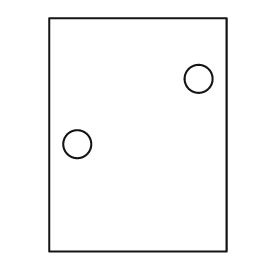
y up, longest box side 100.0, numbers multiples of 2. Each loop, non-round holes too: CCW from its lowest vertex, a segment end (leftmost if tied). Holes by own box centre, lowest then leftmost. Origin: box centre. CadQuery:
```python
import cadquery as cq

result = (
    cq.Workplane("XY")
    .moveTo(-38.0, -50.0)
    .lineTo(38.0, -50.0)
    .lineTo(38.0, 50.0)
    .lineTo(-38.0, 50.0)
    .close()
    .moveTo(-26.0, -4.0)
    .circle(6.0)
    .moveTo(26.0, 24.0)
    .circle(6.0)
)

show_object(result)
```